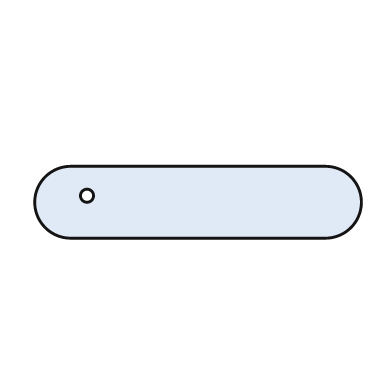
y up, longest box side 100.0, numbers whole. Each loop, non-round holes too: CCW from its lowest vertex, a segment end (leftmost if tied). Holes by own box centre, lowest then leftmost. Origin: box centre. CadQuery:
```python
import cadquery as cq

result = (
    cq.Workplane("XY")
    .moveTo(-39.0, -11.0)
    .lineTo(39.0, -11.0)
    .threePointArc((50.0, 0.0), (39.0, 11.0))
    .lineTo(-39.0, 11.0)
    .threePointArc((-50.0, 0.0), (-39.0, -11.0))
    .close()
    .moveTo(-34.0, 2.0)
    .circle(2.0)
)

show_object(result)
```